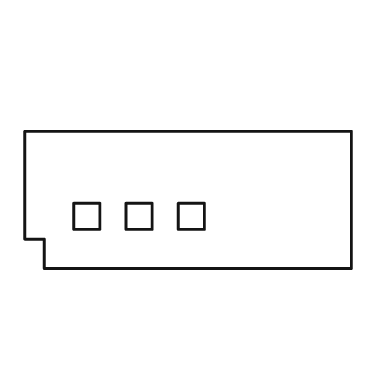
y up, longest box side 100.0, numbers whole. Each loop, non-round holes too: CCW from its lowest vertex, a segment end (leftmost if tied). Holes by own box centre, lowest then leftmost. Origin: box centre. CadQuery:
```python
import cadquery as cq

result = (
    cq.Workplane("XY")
    .moveTo(-44.0, -21.0)
    .lineTo(50.0, -21.0)
    .lineTo(50.0, 21.0)
    .lineTo(-50.0, 21.0)
    .lineTo(-50.0, -12.0)
    .lineTo(-44.0, -12.0)
    .close()
    .moveTo(-35.0, -9.0)
    .lineTo(-27.0, -9.0)
    .lineTo(-27.0, -1.0)
    .lineTo(-35.0, -1.0)
    .close()
    .moveTo(-19.0, -9.0)
    .lineTo(-11.0, -9.0)
    .lineTo(-11.0, -1.0)
    .lineTo(-19.0, -1.0)
    .close()
    .moveTo(-3.0, -9.0)
    .lineTo(5.0, -9.0)
    .lineTo(5.0, -1.0)
    .lineTo(-3.0, -1.0)
    .close()
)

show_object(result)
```